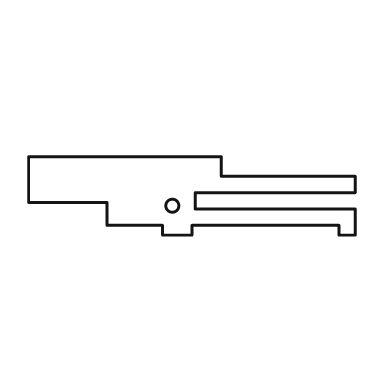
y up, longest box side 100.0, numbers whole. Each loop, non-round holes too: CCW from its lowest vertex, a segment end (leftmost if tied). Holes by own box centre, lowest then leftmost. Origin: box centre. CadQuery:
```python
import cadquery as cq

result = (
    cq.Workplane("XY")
    .moveTo(-9.0, -12.0)
    .lineTo(0.0, -12.0)
    .lineTo(0.0, -9.0)
    .lineTo(45.0, -9.0)
    .lineTo(45.0, -12.0)
    .lineTo(50.0, -12.0)
    .lineTo(50.0, -4.0)
    .lineTo(1.0, -4.0)
    .lineTo(1.0, 1.0)
    .lineTo(50.0, 1.0)
    .lineTo(50.0, 6.0)
    .lineTo(9.0, 6.0)
    .lineTo(9.0, 12.0)
    .lineTo(-50.0, 12.0)
    .lineTo(-50.0, -2.0)
    .lineTo(-26.0, -2.0)
    .lineTo(-26.0, -9.0)
    .lineTo(-9.0, -9.0)
    .close()
    .moveTo(-6.0, -3.0)
    .circle(2.0)
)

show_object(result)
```